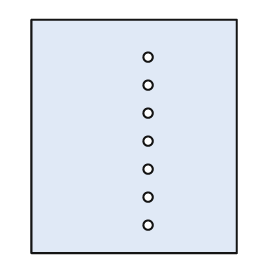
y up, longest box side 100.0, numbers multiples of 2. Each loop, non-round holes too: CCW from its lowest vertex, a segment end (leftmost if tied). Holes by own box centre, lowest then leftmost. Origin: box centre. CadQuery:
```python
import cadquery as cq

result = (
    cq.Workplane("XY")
    .moveTo(-44.0, -50.0)
    .lineTo(44.0, -50.0)
    .lineTo(44.0, 50.0)
    .lineTo(-44.0, 50.0)
    .close()
    .moveTo(6.0, -38.0)
    .circle(2.0)
    .moveTo(6.0, -26.0)
    .circle(2.0)
    .moveTo(6.0, -14.0)
    .circle(2.0)
    .moveTo(6.0, -2.0)
    .circle(2.0)
    .moveTo(6.0, 10.0)
    .circle(2.0)
    .moveTo(6.0, 22.0)
    .circle(2.0)
    .moveTo(6.0, 34.0)
    .circle(2.0)
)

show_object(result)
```